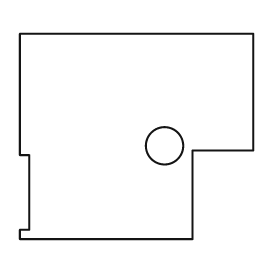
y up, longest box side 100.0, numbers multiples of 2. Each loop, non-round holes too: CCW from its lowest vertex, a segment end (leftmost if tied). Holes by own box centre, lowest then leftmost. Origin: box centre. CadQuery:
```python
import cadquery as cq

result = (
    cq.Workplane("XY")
    .moveTo(-50.0, -44.0)
    .lineTo(24.0, -44.0)
    .lineTo(24.0, -6.0)
    .lineTo(50.0, -6.0)
    .lineTo(50.0, 44.0)
    .lineTo(-50.0, 44.0)
    .lineTo(-50.0, -8.0)
    .lineTo(-46.0, -8.0)
    .lineTo(-46.0, -40.0)
    .lineTo(-50.0, -40.0)
    .close()
    .moveTo(12.0, -4.0)
    .circle(8.0)
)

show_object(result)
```